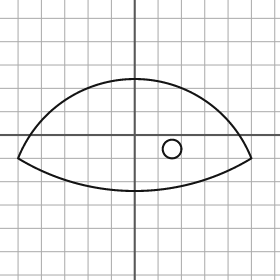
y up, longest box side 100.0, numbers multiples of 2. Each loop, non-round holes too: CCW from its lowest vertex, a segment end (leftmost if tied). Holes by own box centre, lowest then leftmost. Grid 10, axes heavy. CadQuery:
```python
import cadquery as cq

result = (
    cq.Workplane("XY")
    .moveTo(-50.0, -10.0)
    .threePointArc((0.0, -24.0), (50.0, -10.0))
    .threePointArc((0.0, 24.0), (-50.0, -10.0))
    .close()
    .moveTo(16.0, -6.0)
    .circle(4.0)
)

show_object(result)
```